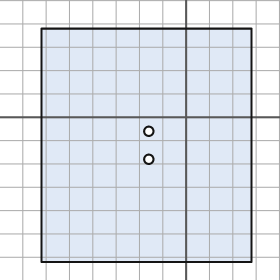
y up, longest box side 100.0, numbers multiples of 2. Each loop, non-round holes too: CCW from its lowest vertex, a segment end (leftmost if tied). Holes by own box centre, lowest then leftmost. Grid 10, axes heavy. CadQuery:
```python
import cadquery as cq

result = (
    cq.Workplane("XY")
    .moveTo(-62.0, -62.0)
    .lineTo(28.0, -62.0)
    .lineTo(28.0, 38.0)
    .lineTo(-62.0, 38.0)
    .close()
    .moveTo(-16.0, -18.0)
    .circle(2.0)
    .moveTo(-16.0, -6.0)
    .circle(2.0)
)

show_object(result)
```